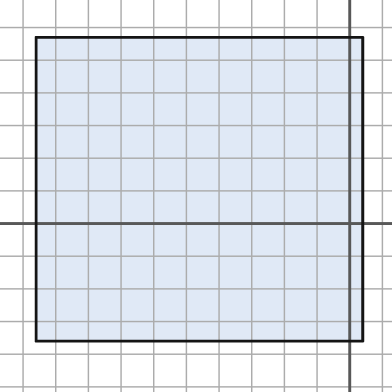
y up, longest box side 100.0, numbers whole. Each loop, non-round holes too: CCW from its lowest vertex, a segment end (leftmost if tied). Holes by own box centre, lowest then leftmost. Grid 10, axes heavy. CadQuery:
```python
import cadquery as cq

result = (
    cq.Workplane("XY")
    .moveTo(-96.0, -36.0)
    .lineTo(4.0, -36.0)
    .lineTo(4.0, 57.0)
    .lineTo(-96.0, 57.0)
    .close()
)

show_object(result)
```